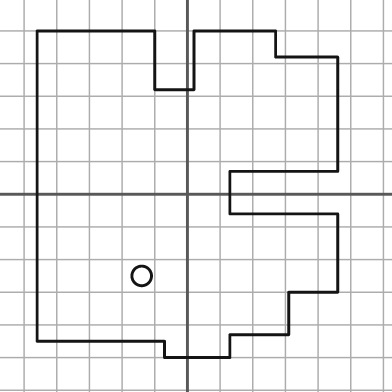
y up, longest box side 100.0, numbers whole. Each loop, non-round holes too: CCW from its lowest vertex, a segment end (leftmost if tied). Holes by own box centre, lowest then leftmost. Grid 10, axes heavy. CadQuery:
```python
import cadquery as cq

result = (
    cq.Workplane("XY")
    .moveTo(-7.0, -50.0)
    .lineTo(13.0, -50.0)
    .lineTo(13.0, -43.0)
    .lineTo(31.0, -43.0)
    .lineTo(31.0, -30.0)
    .lineTo(46.0, -30.0)
    .lineTo(46.0, -6.0)
    .lineTo(13.0, -6.0)
    .lineTo(13.0, 7.0)
    .lineTo(46.0, 7.0)
    .lineTo(46.0, 42.0)
    .lineTo(27.0, 42.0)
    .lineTo(27.0, 50.0)
    .lineTo(2.0, 50.0)
    .lineTo(2.0, 32.0)
    .lineTo(-10.0, 32.0)
    .lineTo(-10.0, 50.0)
    .lineTo(-46.0, 50.0)
    .lineTo(-46.0, -45.0)
    .lineTo(-7.0, -45.0)
    .close()
    .moveTo(-14.0, -25.0)
    .circle(3.0)
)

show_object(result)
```